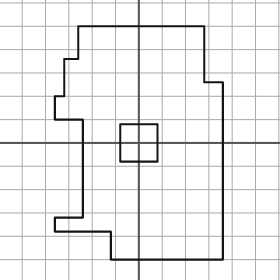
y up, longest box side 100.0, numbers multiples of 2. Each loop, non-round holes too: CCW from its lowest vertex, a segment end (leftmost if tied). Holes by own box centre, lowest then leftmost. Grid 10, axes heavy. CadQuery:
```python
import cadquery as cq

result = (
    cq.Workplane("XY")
    .moveTo(-12.0, -50.0)
    .lineTo(36.0, -50.0)
    .lineTo(36.0, 26.0)
    .lineTo(28.0, 26.0)
    .lineTo(28.0, 50.0)
    .lineTo(-26.0, 50.0)
    .lineTo(-26.0, 36.0)
    .lineTo(-32.0, 36.0)
    .lineTo(-32.0, 20.0)
    .lineTo(-36.0, 20.0)
    .lineTo(-36.0, 10.0)
    .lineTo(-24.0, 10.0)
    .lineTo(-24.0, -32.0)
    .lineTo(-36.0, -32.0)
    .lineTo(-36.0, -38.0)
    .lineTo(-12.0, -38.0)
    .close()
    .moveTo(-8.0, -8.0)
    .lineTo(8.0, -8.0)
    .lineTo(8.0, 8.0)
    .lineTo(-8.0, 8.0)
    .close()
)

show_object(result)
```